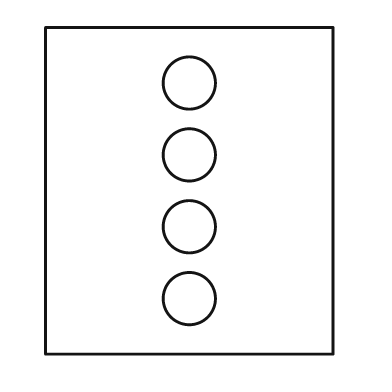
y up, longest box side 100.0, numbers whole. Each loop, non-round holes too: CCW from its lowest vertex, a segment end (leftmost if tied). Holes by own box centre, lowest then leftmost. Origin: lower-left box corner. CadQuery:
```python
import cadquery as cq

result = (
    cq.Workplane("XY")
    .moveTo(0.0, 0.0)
    .lineTo(88.0, 0.0)
    .lineTo(88.0, 100.0)
    .lineTo(0.0, 100.0)
    .close()
    .moveTo(44.0, 17.0)
    .circle(8.0)
    .moveTo(44.0, 39.0)
    .circle(8.0)
    .moveTo(44.0, 61.0)
    .circle(8.0)
    .moveTo(44.0, 83.0)
    .circle(8.0)
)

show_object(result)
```